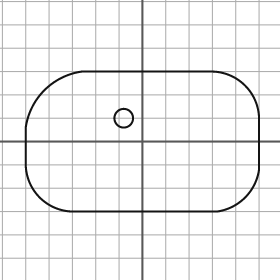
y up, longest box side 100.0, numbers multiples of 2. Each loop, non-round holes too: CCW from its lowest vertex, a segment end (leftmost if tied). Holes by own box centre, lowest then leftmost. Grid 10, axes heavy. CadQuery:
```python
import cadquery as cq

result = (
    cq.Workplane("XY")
    .moveTo(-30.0, -30.0)
    .lineTo(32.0, -30.0)
    .threePointArc((44.0, -24.0), (50.0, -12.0))
    .lineTo(50.0, 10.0)
    .threePointArc((44.0, 24.0), (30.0, 30.0))
    .lineTo(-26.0, 30.0)
    .threePointArc((-42.0, 22.0), (-50.0, 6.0))
    .lineTo(-50.0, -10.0)
    .threePointArc((-44.0, -24.0), (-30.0, -30.0))
    .close()
    .moveTo(-8.0, 10.0)
    .circle(4.0)
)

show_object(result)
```